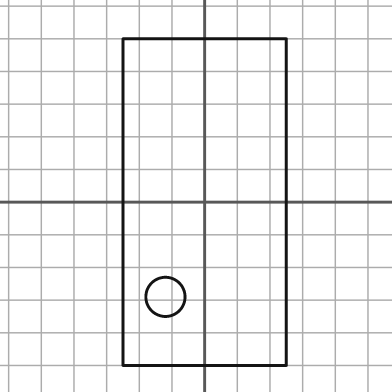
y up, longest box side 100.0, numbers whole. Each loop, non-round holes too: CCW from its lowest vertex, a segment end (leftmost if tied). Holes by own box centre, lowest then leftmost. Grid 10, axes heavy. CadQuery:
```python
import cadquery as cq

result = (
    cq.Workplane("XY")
    .moveTo(-25.0, -50.0)
    .lineTo(25.0, -50.0)
    .lineTo(25.0, 50.0)
    .lineTo(-25.0, 50.0)
    .close()
    .moveTo(-12.0, -29.0)
    .circle(6.0)
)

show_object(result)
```